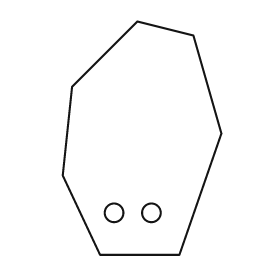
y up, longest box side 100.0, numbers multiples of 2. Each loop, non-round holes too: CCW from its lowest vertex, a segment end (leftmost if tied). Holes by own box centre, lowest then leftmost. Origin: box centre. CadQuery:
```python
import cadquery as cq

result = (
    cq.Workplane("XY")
    .moveTo(-18.0, -50.0)
    .lineTo(16.0, -50.0)
    .lineTo(34.0, 2.0)
    .lineTo(22.0, 44.0)
    .lineTo(-2.0, 50.0)
    .lineTo(-30.0, 22.0)
    .lineTo(-34.0, -16.0)
    .close()
    .moveTo(-12.0, -32.0)
    .circle(4.0)
    .moveTo(4.0, -32.0)
    .circle(4.0)
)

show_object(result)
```